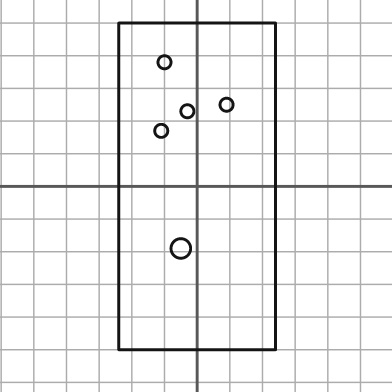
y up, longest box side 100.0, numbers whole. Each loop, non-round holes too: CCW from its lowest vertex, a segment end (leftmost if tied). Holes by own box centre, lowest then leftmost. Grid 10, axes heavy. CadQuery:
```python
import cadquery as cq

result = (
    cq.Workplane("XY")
    .moveTo(-24.0, -50.0)
    .lineTo(24.0, -50.0)
    .lineTo(24.0, 50.0)
    .lineTo(-24.0, 50.0)
    .close()
    .moveTo(-5.0, -19.0)
    .circle(3.0)
    .moveTo(-11.0, 17.0)
    .circle(2.0)
    .moveTo(-3.0, 23.0)
    .circle(2.0)
    .moveTo(9.0, 25.0)
    .circle(2.0)
    .moveTo(-10.0, 38.0)
    .circle(2.0)
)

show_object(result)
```